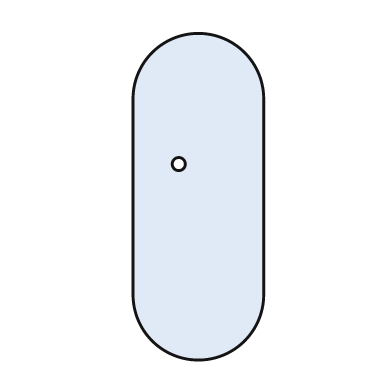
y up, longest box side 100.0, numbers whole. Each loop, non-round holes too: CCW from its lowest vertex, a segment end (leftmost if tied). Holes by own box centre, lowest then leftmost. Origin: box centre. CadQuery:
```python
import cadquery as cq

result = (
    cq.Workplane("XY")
    .moveTo(-20.0, -30.0)
    .threePointArc((0.0, -50.0), (20.0, -30.0))
    .lineTo(20.0, 30.0)
    .threePointArc((0.0, 50.0), (-20.0, 30.0))
    .close()
    .moveTo(-6.0, 10.0)
    .circle(2.0)
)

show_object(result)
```